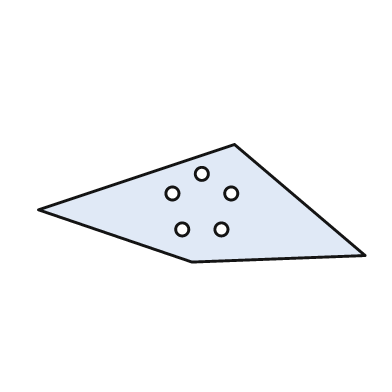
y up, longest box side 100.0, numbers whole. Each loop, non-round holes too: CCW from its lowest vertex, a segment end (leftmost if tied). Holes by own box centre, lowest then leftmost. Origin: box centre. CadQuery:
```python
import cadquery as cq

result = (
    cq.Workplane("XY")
    .moveTo(-3.0, -18.0)
    .lineTo(50.0, -16.0)
    .lineTo(10.0, 18.0)
    .lineTo(-50.0, -2.0)
    .close()
    .moveTo(-6.0, -8.0)
    .circle(2.0)
    .moveTo(6.0, -8.0)
    .circle(2.0)
    .moveTo(-9.0, 3.0)
    .circle(2.0)
    .moveTo(9.0, 3.0)
    .circle(2.0)
    .moveTo(0.0, 9.0)
    .circle(2.0)
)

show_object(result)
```